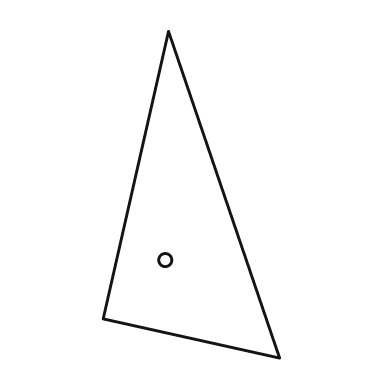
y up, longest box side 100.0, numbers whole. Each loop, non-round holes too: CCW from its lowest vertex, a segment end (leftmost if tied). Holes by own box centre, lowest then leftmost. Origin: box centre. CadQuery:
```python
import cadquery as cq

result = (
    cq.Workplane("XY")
    .moveTo(27.0, -50.0)
    .lineTo(-7.0, 50.0)
    .lineTo(-27.0, -38.0)
    .close()
    .moveTo(-8.0, -20.0)
    .circle(2.0)
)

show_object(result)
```